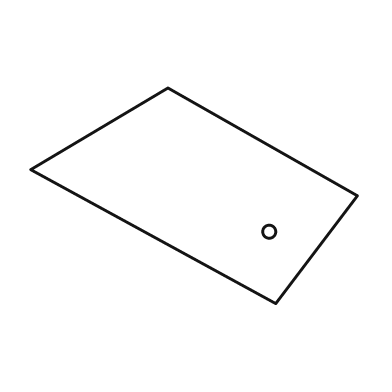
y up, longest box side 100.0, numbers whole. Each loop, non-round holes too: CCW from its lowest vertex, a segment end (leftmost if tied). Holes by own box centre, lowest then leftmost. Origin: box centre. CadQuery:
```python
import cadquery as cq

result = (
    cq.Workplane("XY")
    .moveTo(25.0, -33.0)
    .lineTo(50.0, 0.0)
    .lineTo(-8.0, 33.0)
    .lineTo(-50.0, 8.0)
    .close()
    .moveTo(23.0, -11.0)
    .circle(2.0)
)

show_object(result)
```